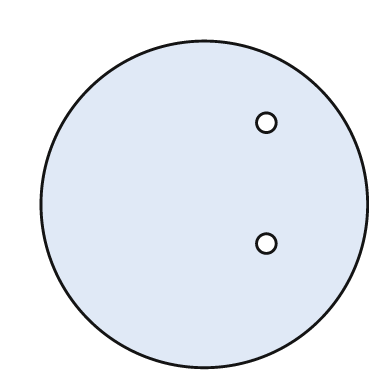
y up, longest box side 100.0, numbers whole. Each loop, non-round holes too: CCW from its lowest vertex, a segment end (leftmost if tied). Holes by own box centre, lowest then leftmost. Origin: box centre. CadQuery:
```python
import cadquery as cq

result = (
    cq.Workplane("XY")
    .moveTo(0.0, 0.0)
    .circle(50.0)
    .moveTo(19.0, -12.0)
    .circle(3.0)
    .moveTo(19.0, 25.0)
    .circle(3.0)
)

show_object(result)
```